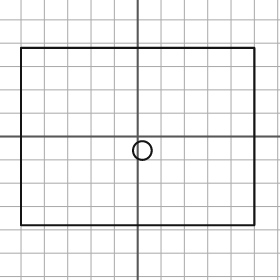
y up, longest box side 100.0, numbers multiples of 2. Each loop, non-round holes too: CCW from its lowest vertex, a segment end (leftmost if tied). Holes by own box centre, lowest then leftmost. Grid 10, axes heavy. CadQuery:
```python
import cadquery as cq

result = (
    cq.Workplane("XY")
    .moveTo(-50.0, -38.0)
    .lineTo(50.0, -38.0)
    .lineTo(50.0, 38.0)
    .lineTo(-50.0, 38.0)
    .close()
    .moveTo(2.0, -6.0)
    .circle(4.0)
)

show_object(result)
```